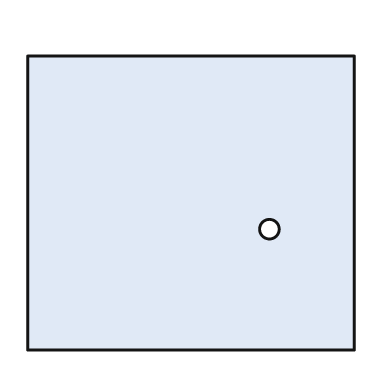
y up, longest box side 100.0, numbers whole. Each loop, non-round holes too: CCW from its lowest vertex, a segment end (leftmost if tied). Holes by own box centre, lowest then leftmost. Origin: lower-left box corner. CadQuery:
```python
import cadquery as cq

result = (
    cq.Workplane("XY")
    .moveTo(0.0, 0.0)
    .lineTo(100.0, 0.0)
    .lineTo(100.0, 90.0)
    .lineTo(0.0, 90.0)
    .close()
    .moveTo(74.0, 37.0)
    .circle(3.0)
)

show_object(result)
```